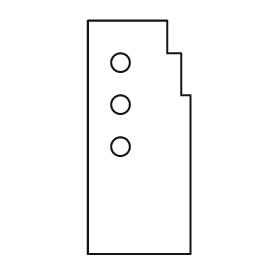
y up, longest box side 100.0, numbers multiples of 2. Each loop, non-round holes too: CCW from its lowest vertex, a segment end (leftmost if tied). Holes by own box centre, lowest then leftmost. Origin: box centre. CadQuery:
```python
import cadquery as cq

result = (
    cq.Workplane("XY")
    .moveTo(-22.0, -50.0)
    .lineTo(22.0, -50.0)
    .lineTo(22.0, 18.0)
    .lineTo(18.0, 18.0)
    .lineTo(18.0, 36.0)
    .lineTo(12.0, 36.0)
    .lineTo(12.0, 50.0)
    .lineTo(-22.0, 50.0)
    .close()
    .moveTo(-8.0, -4.0)
    .circle(4.0)
    .moveTo(-8.0, 14.0)
    .circle(4.0)
    .moveTo(-8.0, 32.0)
    .circle(4.0)
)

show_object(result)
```